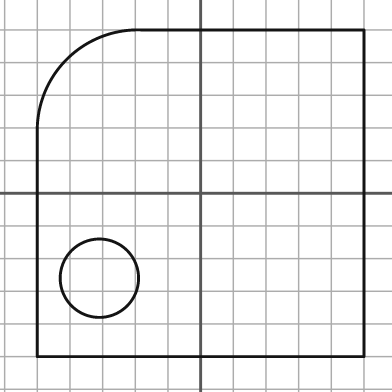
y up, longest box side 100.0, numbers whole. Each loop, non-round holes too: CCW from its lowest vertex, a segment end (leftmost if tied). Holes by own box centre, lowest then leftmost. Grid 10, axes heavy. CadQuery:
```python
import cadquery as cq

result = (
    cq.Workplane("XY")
    .moveTo(-50.0, -50.0)
    .lineTo(50.0, -50.0)
    .lineTo(50.0, 50.0)
    .lineTo(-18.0, 50.0)
    .threePointArc((-41.0, 41.0), (-50.0, 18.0))
    .close()
    .moveTo(-31.0, -26.0)
    .circle(12.0)
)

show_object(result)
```